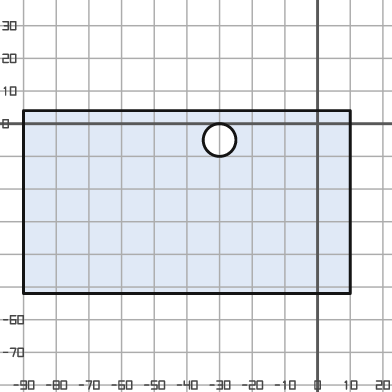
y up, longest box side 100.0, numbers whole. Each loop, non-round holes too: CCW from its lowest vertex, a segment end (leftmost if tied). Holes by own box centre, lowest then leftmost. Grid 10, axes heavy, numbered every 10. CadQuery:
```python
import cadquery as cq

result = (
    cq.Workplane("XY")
    .moveTo(-90.0, -52.0)
    .lineTo(10.0, -52.0)
    .lineTo(10.0, 4.0)
    .lineTo(-90.0, 4.0)
    .close()
    .moveTo(-30.0, -5.0)
    .circle(5.0)
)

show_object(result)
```